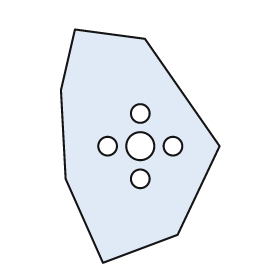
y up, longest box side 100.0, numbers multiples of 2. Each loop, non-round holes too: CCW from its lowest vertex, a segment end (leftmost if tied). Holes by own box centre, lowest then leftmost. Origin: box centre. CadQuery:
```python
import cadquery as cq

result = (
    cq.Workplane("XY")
    .moveTo(-16.0, -50.0)
    .lineTo(16.0, -38.0)
    .lineTo(34.0, 0.0)
    .lineTo(2.0, 46.0)
    .lineTo(-28.0, 50.0)
    .lineTo(-34.0, 24.0)
    .lineTo(-32.0, -14.0)
    .close()
    .moveTo(0.0, -14.0)
    .circle(4.0)
    .moveTo(-14.0, 0.0)
    .circle(4.0)
    .moveTo(0.0, 0.0)
    .circle(6.0)
    .moveTo(14.0, 0.0)
    .circle(4.0)
    .moveTo(0.0, 14.0)
    .circle(4.0)
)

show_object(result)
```